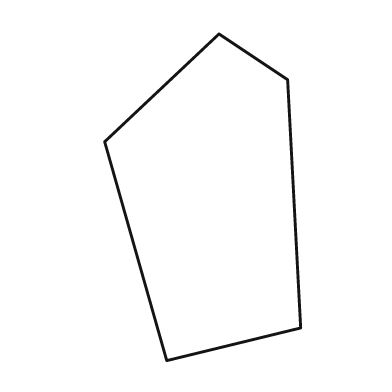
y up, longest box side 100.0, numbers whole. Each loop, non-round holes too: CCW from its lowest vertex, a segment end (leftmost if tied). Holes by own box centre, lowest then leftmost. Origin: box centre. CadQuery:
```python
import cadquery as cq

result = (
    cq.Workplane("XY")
    .moveTo(-11.0, -50.0)
    .lineTo(30.0, -40.0)
    .lineTo(26.0, 36.0)
    .lineTo(5.0, 50.0)
    .lineTo(-30.0, 17.0)
    .close()
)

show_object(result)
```